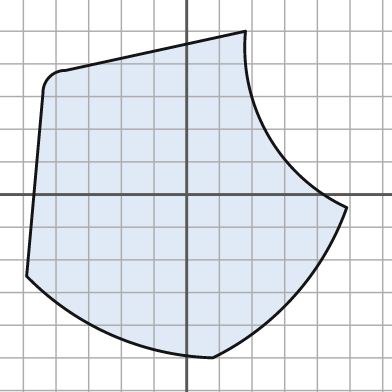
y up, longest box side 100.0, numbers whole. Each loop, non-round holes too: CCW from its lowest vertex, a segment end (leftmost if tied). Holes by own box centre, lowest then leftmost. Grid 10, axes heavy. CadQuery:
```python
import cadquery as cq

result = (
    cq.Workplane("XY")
    .moveTo(8.0, -50.0)
    .threePointArc((33.0, -31.0), (49.0, -4.0))
    .threePointArc((25.0, 18.0), (18.0, 50.0))
    .lineTo(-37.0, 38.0)
    .threePointArc((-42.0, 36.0), (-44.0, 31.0))
    .lineTo(-49.0, -25.0)
    .threePointArc((-23.0, -43.0), (8.0, -50.0))
    .close()
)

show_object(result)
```